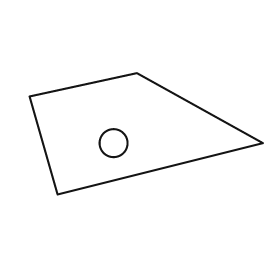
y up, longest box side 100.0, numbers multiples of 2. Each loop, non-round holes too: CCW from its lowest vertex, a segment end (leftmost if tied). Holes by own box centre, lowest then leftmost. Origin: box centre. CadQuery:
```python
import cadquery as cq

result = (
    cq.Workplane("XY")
    .moveTo(-38.0, -26.0)
    .lineTo(50.0, -4.0)
    .lineTo(-4.0, 26.0)
    .lineTo(-50.0, 16.0)
    .close()
    .moveTo(-14.0, -4.0)
    .circle(6.0)
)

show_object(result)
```